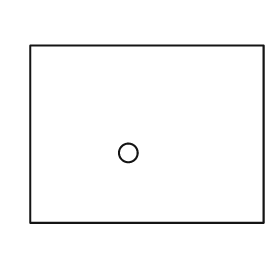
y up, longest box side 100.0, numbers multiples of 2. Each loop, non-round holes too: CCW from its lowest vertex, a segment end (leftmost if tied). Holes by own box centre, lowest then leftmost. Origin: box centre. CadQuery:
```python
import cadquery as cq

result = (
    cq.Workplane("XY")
    .moveTo(-50.0, -38.0)
    .lineTo(50.0, -38.0)
    .lineTo(50.0, 38.0)
    .lineTo(-50.0, 38.0)
    .close()
    .moveTo(-8.0, -8.0)
    .circle(4.0)
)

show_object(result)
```